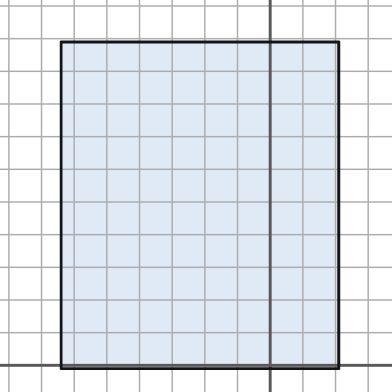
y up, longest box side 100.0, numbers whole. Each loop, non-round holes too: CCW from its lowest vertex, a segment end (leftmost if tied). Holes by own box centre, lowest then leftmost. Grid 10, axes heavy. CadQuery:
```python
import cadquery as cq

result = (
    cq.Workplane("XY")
    .moveTo(-64.0, -1.0)
    .lineTo(21.0, -1.0)
    .lineTo(21.0, 99.0)
    .lineTo(-64.0, 99.0)
    .close()
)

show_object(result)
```